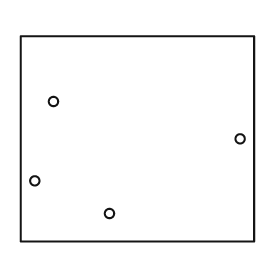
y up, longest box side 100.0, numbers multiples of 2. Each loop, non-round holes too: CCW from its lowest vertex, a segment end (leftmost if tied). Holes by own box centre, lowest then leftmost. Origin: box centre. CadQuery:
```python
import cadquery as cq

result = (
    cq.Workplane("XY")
    .moveTo(-50.0, -44.0)
    .lineTo(50.0, -44.0)
    .lineTo(50.0, 44.0)
    .lineTo(-50.0, 44.0)
    .close()
    .moveTo(-12.0, -32.0)
    .circle(2.0)
    .moveTo(-44.0, -18.0)
    .circle(2.0)
    .moveTo(44.0, 0.0)
    .circle(2.0)
    .moveTo(-36.0, 16.0)
    .circle(2.0)
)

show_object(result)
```